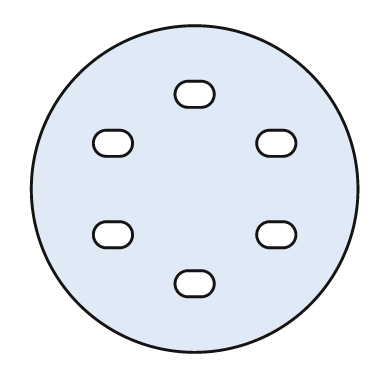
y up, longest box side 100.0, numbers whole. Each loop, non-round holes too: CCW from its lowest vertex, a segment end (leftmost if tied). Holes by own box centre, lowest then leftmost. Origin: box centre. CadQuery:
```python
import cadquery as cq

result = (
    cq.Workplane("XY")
    .moveTo(0.0, 0.0)
    .circle(50.0)
    .moveTo(-2.0, -33.0)
    .lineTo(2.0, -33.0)
    .threePointArc((6.0, -29.0), (2.0, -25.0))
    .lineTo(-2.0, -25.0)
    .threePointArc((-6.0, -29.0), (-2.0, -33.0))
    .close()
    .moveTo(-27.0, -18.0)
    .lineTo(-23.0, -18.0)
    .threePointArc((-19.0, -14.0), (-23.0, -10.0))
    .lineTo(-27.0, -10.0)
    .threePointArc((-31.0, -14.0), (-27.0, -18.0))
    .close()
    .moveTo(23.0, -18.0)
    .lineTo(27.0, -18.0)
    .threePointArc((31.0, -14.0), (27.0, -10.0))
    .lineTo(23.0, -10.0)
    .threePointArc((19.0, -14.0), (23.0, -18.0))
    .close()
    .moveTo(-27.0, 10.0)
    .lineTo(-23.0, 10.0)
    .threePointArc((-19.0, 14.0), (-23.0, 18.0))
    .lineTo(-27.0, 18.0)
    .threePointArc((-31.0, 14.0), (-27.0, 10.0))
    .close()
    .moveTo(23.0, 10.0)
    .lineTo(27.0, 10.0)
    .threePointArc((31.0, 14.0), (27.0, 18.0))
    .lineTo(23.0, 18.0)
    .threePointArc((19.0, 14.0), (23.0, 10.0))
    .close()
    .moveTo(-2.0, 25.0)
    .lineTo(2.0, 25.0)
    .threePointArc((6.0, 29.0), (2.0, 33.0))
    .lineTo(-2.0, 33.0)
    .threePointArc((-6.0, 29.0), (-2.0, 25.0))
    .close()
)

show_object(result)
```